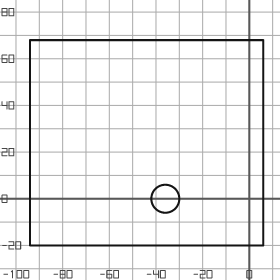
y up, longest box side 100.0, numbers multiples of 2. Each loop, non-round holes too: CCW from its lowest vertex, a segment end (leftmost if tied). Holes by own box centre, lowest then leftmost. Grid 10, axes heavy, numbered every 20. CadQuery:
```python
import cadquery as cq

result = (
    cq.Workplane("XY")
    .moveTo(-94.0, -20.0)
    .lineTo(6.0, -20.0)
    .lineTo(6.0, 68.0)
    .lineTo(-94.0, 68.0)
    .close()
    .moveTo(-36.0, 0.0)
    .circle(6.0)
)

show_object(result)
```